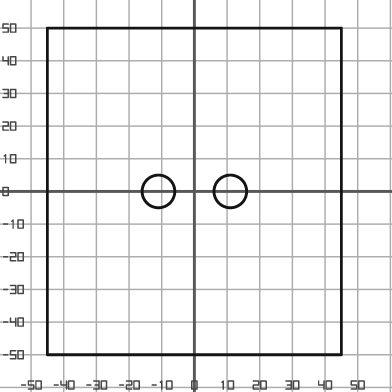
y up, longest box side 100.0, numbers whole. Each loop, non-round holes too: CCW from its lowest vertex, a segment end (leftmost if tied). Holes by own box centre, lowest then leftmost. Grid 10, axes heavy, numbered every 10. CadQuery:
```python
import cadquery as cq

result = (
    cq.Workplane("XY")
    .moveTo(-45.0, -50.0)
    .lineTo(45.0, -50.0)
    .lineTo(45.0, 50.0)
    .lineTo(-45.0, 50.0)
    .close()
    .moveTo(-11.0, 0.0)
    .circle(5.0)
    .moveTo(11.0, 0.0)
    .circle(5.0)
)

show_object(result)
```